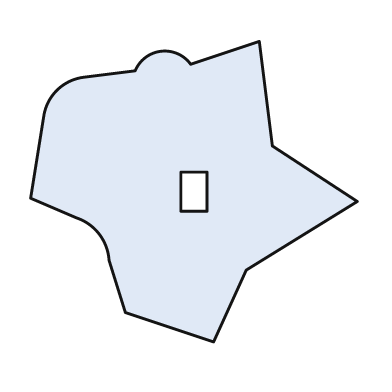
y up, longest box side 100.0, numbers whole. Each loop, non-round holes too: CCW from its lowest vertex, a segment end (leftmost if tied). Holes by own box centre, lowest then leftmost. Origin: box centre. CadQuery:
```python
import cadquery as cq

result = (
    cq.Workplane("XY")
    .moveTo(6.0, -46.0)
    .lineTo(16.0, -24.0)
    .lineTo(50.0, -3.0)
    .lineTo(24.0, 14.0)
    .lineTo(20.0, 46.0)
    .lineTo(-1.0, 39.0)
    .threePointArc((-10.0, 43.0), (-18.0, 37.0))
    .lineTo(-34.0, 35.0)
    .threePointArc((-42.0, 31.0), (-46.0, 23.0))
    .lineTo(-50.0, -2.0)
    .lineTo(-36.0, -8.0)
    .threePointArc((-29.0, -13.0), (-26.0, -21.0))
    .lineTo(-21.0, -37.0)
    .close()
    .moveTo(-4.0, -6.0)
    .lineTo(4.0, -6.0)
    .lineTo(4.0, 6.0)
    .lineTo(-4.0, 6.0)
    .close()
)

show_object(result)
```